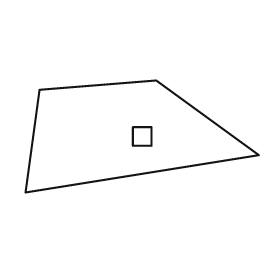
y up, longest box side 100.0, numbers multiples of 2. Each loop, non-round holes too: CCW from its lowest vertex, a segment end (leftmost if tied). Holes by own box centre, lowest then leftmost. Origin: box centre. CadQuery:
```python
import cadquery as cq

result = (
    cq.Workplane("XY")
    .moveTo(-50.0, -24.0)
    .lineTo(50.0, -8.0)
    .lineTo(6.0, 24.0)
    .lineTo(-44.0, 20.0)
    .close()
    .moveTo(-4.0, -4.0)
    .lineTo(4.0, -4.0)
    .lineTo(4.0, 4.0)
    .lineTo(-4.0, 4.0)
    .close()
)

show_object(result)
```